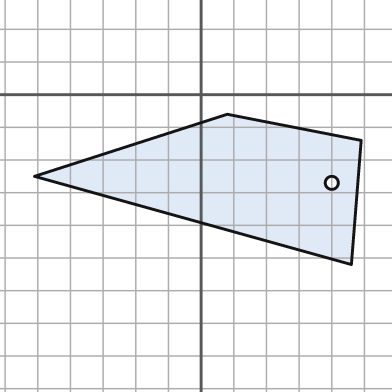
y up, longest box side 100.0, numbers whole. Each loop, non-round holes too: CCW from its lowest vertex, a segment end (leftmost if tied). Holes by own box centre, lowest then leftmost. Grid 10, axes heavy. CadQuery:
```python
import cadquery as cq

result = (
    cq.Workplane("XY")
    .moveTo(46.0, -52.0)
    .lineTo(49.0, -14.0)
    .lineTo(8.0, -6.0)
    .lineTo(-51.0, -25.0)
    .close()
    .moveTo(40.0, -27.0)
    .circle(2.0)
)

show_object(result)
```